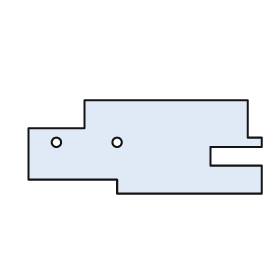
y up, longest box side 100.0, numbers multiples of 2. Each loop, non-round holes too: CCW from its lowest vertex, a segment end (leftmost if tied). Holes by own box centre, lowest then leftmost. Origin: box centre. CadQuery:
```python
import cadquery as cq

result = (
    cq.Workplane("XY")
    .moveTo(-12.0, -20.0)
    .lineTo(50.0, -20.0)
    .lineTo(50.0, -8.0)
    .lineTo(28.0, -8.0)
    .lineTo(28.0, 0.0)
    .lineTo(50.0, 0.0)
    .lineTo(50.0, 4.0)
    .lineTo(44.0, 4.0)
    .lineTo(44.0, 20.0)
    .lineTo(-26.0, 20.0)
    .lineTo(-26.0, 8.0)
    .lineTo(-50.0, 8.0)
    .lineTo(-50.0, -14.0)
    .lineTo(-12.0, -14.0)
    .close()
    .moveTo(-38.0, 2.0)
    .circle(2.0)
    .moveTo(-12.0, 2.0)
    .circle(2.0)
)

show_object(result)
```